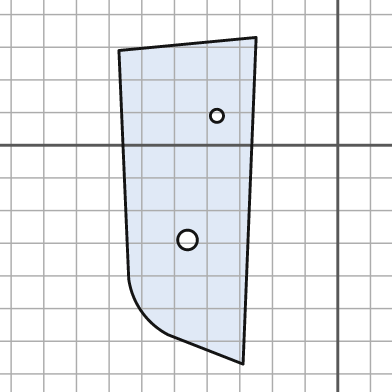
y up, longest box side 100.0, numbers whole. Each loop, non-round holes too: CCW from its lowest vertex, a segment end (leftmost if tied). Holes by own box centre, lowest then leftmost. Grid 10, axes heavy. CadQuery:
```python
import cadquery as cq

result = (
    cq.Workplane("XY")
    .moveTo(-29.0, -67.0)
    .lineTo(-25.0, 33.0)
    .lineTo(-67.0, 29.0)
    .lineTo(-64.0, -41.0)
    .threePointArc((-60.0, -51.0), (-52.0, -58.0))
    .close()
    .moveTo(-46.0, -29.0)
    .circle(3.0)
    .moveTo(-37.0, 9.0)
    .circle(2.0)
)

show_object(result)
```